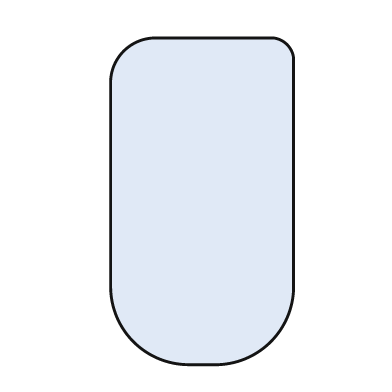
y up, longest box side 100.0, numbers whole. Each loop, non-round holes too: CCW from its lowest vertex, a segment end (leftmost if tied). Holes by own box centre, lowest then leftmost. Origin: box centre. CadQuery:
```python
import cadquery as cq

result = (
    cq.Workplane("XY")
    .moveTo(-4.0, -50.0)
    .lineTo(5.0, -50.0)
    .threePointArc((21.0, -43.0), (28.0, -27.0))
    .lineTo(28.0, 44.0)
    .threePointArc((26.0, 48.0), (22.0, 50.0))
    .lineTo(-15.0, 50.0)
    .threePointArc((-24.0, 46.0), (-28.0, 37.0))
    .lineTo(-28.0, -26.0)
    .threePointArc((-21.0, -43.0), (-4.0, -50.0))
    .close()
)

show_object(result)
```